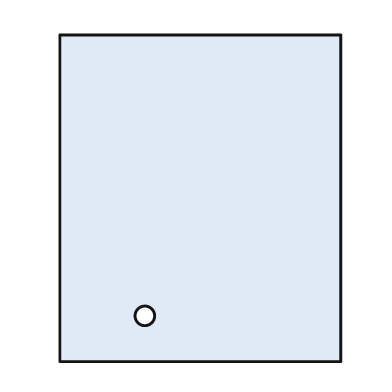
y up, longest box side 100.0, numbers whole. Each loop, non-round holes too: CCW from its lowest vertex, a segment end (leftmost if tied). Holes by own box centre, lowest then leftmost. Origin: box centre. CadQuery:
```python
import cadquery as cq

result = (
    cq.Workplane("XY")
    .moveTo(-43.0, -50.0)
    .lineTo(43.0, -50.0)
    .lineTo(43.0, 50.0)
    .lineTo(-43.0, 50.0)
    .close()
    .moveTo(-17.0, -36.0)
    .circle(3.0)
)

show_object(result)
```